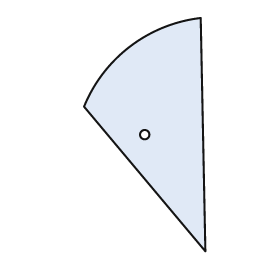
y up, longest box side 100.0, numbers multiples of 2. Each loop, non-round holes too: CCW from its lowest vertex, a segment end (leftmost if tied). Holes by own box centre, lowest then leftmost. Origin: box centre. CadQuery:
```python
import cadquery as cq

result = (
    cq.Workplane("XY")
    .moveTo(26.0, -50.0)
    .lineTo(24.0, 50.0)
    .threePointArc((-6.0, 38.0), (-26.0, 12.0))
    .close()
    .moveTo(0.0, 0.0)
    .circle(2.0)
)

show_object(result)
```